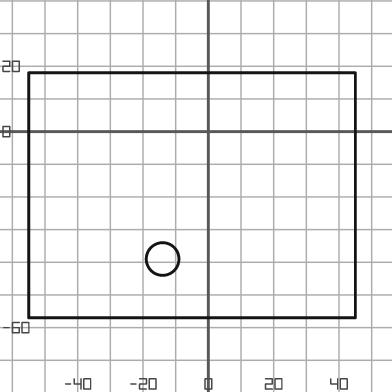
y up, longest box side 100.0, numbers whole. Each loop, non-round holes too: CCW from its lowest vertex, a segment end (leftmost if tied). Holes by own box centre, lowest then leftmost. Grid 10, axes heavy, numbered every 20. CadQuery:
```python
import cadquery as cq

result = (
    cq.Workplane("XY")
    .moveTo(-55.0, -57.0)
    .lineTo(45.0, -57.0)
    .lineTo(45.0, 18.0)
    .lineTo(-55.0, 18.0)
    .close()
    .moveTo(-14.0, -39.0)
    .circle(5.0)
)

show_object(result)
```